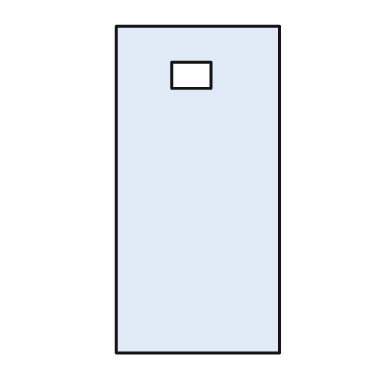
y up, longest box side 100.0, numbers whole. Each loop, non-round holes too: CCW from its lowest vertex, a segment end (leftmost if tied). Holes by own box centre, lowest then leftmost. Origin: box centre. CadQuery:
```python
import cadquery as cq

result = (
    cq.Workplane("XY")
    .moveTo(-25.0, -50.0)
    .lineTo(25.0, -50.0)
    .lineTo(25.0, 50.0)
    .lineTo(-25.0, 50.0)
    .close()
    .moveTo(-8.0, 31.0)
    .lineTo(4.0, 31.0)
    .lineTo(4.0, 39.0)
    .lineTo(-8.0, 39.0)
    .close()
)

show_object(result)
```